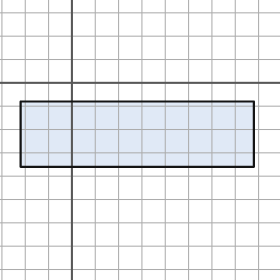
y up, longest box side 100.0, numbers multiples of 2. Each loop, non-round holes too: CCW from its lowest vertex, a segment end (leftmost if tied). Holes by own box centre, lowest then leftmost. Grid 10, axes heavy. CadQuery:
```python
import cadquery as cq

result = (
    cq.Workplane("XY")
    .moveTo(-22.0, -36.0)
    .lineTo(78.0, -36.0)
    .lineTo(78.0, -8.0)
    .lineTo(-22.0, -8.0)
    .close()
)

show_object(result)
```